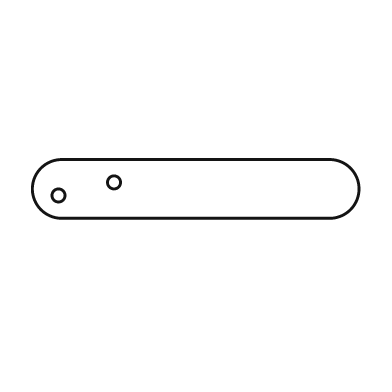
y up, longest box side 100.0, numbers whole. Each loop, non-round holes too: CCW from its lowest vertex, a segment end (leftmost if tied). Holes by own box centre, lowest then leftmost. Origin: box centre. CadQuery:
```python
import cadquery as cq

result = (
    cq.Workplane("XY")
    .moveTo(-41.0, -9.0)
    .lineTo(41.0, -9.0)
    .threePointArc((50.0, 0.0), (41.0, 9.0))
    .lineTo(-41.0, 9.0)
    .threePointArc((-50.0, 0.0), (-41.0, -9.0))
    .close()
    .moveTo(-42.0, -2.0)
    .circle(2.0)
    .moveTo(-25.0, 2.0)
    .circle(2.0)
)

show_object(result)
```